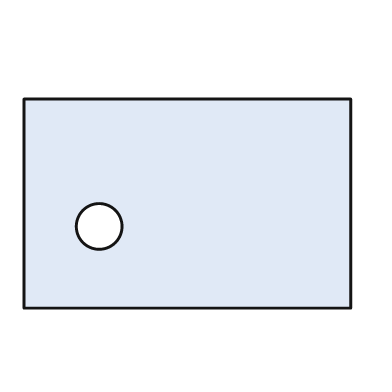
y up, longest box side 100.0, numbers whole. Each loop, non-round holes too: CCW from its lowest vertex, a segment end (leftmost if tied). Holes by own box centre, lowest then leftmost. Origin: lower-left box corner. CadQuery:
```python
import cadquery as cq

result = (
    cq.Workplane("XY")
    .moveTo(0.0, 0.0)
    .lineTo(100.0, 0.0)
    .lineTo(100.0, 64.0)
    .lineTo(0.0, 64.0)
    .close()
    .moveTo(23.0, 25.0)
    .circle(7.0)
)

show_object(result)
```